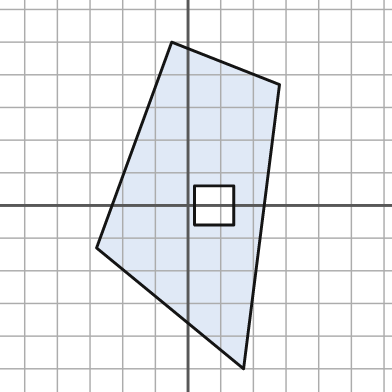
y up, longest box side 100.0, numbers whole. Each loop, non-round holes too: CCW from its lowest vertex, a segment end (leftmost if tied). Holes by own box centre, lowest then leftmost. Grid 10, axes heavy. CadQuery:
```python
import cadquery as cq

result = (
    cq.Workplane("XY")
    .moveTo(17.0, -50.0)
    .lineTo(28.0, 37.0)
    .lineTo(-5.0, 50.0)
    .lineTo(-28.0, -13.0)
    .close()
    .moveTo(2.0, -6.0)
    .lineTo(14.0, -6.0)
    .lineTo(14.0, 6.0)
    .lineTo(2.0, 6.0)
    .close()
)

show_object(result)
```